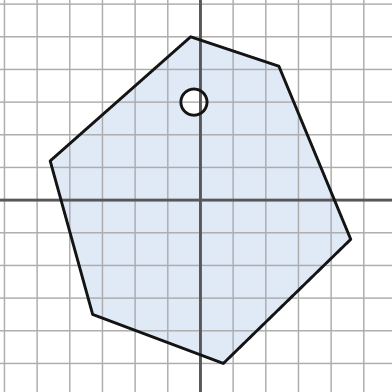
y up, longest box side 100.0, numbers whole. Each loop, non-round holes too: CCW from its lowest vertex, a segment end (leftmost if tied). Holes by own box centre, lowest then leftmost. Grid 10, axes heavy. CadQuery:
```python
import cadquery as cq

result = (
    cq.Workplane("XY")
    .moveTo(7.0, -50.0)
    .lineTo(46.0, -12.0)
    .lineTo(24.0, 41.0)
    .lineTo(-3.0, 50.0)
    .lineTo(-46.0, 12.0)
    .lineTo(-33.0, -35.0)
    .close()
    .moveTo(-2.0, 30.0)
    .circle(4.0)
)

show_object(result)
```